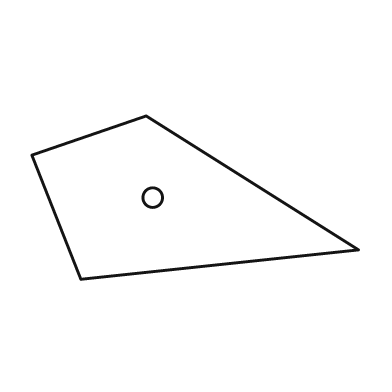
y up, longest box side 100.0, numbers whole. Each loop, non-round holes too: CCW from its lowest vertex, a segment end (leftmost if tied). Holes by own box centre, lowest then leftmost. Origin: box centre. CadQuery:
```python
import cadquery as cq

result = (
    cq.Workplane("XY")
    .moveTo(-35.0, -25.0)
    .lineTo(50.0, -16.0)
    .lineTo(-15.0, 25.0)
    .lineTo(-50.0, 13.0)
    .close()
    .moveTo(-13.0, 0.0)
    .circle(3.0)
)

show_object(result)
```